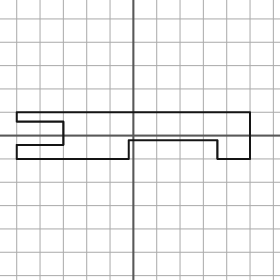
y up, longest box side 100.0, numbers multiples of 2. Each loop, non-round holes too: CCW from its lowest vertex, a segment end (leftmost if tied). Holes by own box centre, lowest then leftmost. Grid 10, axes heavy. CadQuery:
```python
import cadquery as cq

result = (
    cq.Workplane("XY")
    .moveTo(-50.0, -10.0)
    .lineTo(-2.0, -10.0)
    .lineTo(-2.0, -2.0)
    .lineTo(36.0, -2.0)
    .lineTo(36.0, -10.0)
    .lineTo(50.0, -10.0)
    .lineTo(50.0, 10.0)
    .lineTo(-50.0, 10.0)
    .lineTo(-50.0, 6.0)
    .lineTo(-30.0, 6.0)
    .lineTo(-30.0, -4.0)
    .lineTo(-50.0, -4.0)
    .close()
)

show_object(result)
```